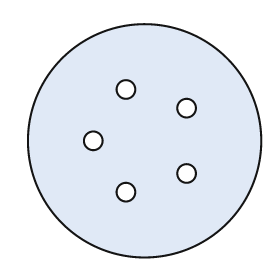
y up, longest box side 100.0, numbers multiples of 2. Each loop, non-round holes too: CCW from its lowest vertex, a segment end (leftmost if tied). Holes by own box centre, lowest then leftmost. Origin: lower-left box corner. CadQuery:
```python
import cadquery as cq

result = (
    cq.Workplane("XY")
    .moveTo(50.0, 50.0)
    .circle(50.0)
    .moveTo(42.0, 28.0)
    .circle(4.0)
    .moveTo(68.0, 36.0)
    .circle(4.0)
    .moveTo(28.0, 50.0)
    .circle(4.0)
    .moveTo(68.0, 64.0)
    .circle(4.0)
    .moveTo(42.0, 72.0)
    .circle(4.0)
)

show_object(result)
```